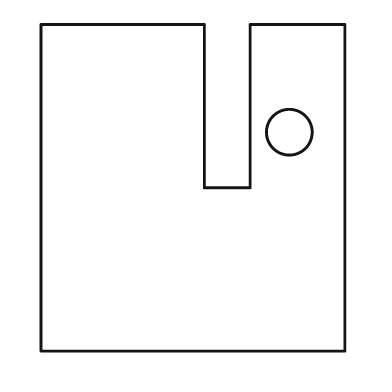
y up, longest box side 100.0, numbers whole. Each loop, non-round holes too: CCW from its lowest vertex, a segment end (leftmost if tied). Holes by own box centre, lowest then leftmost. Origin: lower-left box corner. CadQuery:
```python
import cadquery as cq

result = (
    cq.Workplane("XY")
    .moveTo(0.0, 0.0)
    .lineTo(93.0, 0.0)
    .lineTo(93.0, 100.0)
    .lineTo(64.0, 100.0)
    .lineTo(64.0, 50.0)
    .lineTo(50.0, 50.0)
    .lineTo(50.0, 100.0)
    .lineTo(0.0, 100.0)
    .close()
    .moveTo(76.0, 67.0)
    .circle(7.0)
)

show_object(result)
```